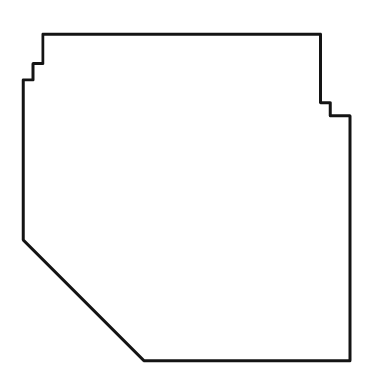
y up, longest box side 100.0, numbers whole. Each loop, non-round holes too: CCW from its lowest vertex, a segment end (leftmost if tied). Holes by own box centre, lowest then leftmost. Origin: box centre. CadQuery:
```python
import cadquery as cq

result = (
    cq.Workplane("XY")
    .moveTo(-13.0, -50.0)
    .lineTo(50.0, -50.0)
    .lineTo(50.0, 25.0)
    .lineTo(44.0, 25.0)
    .lineTo(44.0, 29.0)
    .lineTo(41.0, 29.0)
    .lineTo(41.0, 50.0)
    .lineTo(-44.0, 50.0)
    .lineTo(-44.0, 41.0)
    .lineTo(-47.0, 41.0)
    .lineTo(-47.0, 36.0)
    .lineTo(-50.0, 36.0)
    .lineTo(-50.0, -13.0)
    .close()
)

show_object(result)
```